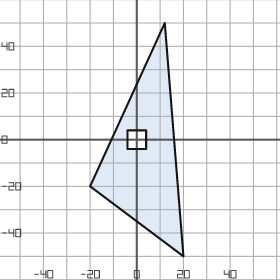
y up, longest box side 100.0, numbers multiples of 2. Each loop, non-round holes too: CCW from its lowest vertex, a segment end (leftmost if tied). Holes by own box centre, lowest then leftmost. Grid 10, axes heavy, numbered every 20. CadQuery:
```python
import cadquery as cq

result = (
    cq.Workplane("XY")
    .moveTo(20.0, -50.0)
    .lineTo(12.0, 50.0)
    .lineTo(-20.0, -20.0)
    .close()
    .moveTo(-4.0, -4.0)
    .lineTo(4.0, -4.0)
    .lineTo(4.0, 4.0)
    .lineTo(-4.0, 4.0)
    .close()
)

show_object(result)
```